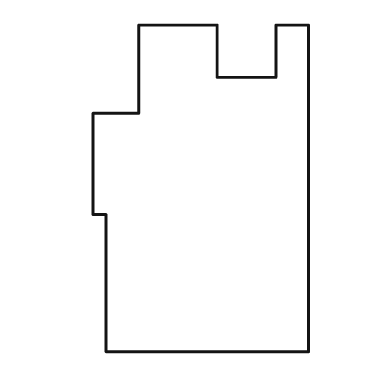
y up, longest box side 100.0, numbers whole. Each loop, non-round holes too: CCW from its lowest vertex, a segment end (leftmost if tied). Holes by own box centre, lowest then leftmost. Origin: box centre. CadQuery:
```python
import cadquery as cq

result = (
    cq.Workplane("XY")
    .moveTo(-29.0, -50.0)
    .lineTo(33.0, -50.0)
    .lineTo(33.0, 50.0)
    .lineTo(23.0, 50.0)
    .lineTo(23.0, 34.0)
    .lineTo(5.0, 34.0)
    .lineTo(5.0, 50.0)
    .lineTo(-19.0, 50.0)
    .lineTo(-19.0, 23.0)
    .lineTo(-33.0, 23.0)
    .lineTo(-33.0, -8.0)
    .lineTo(-29.0, -8.0)
    .close()
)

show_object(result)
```